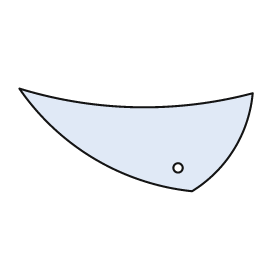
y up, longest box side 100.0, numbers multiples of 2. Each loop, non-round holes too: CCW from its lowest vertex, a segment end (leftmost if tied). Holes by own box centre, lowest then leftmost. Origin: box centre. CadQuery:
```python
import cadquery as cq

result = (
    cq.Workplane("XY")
    .moveTo(24.0, -22.0)
    .threePointArc((42.0, -4.0), (50.0, 20.0))
    .threePointArc((0.0, 14.0), (-50.0, 22.0))
    .threePointArc((-18.0, -8.0), (24.0, -22.0))
    .close()
    .moveTo(18.0, -12.0)
    .circle(2.0)
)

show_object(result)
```